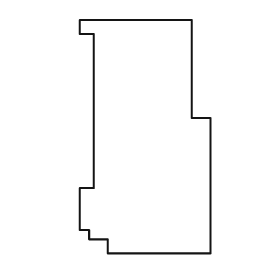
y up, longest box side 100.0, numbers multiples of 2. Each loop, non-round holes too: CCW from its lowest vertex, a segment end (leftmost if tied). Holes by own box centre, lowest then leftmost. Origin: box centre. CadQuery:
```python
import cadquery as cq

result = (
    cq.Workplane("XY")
    .moveTo(-16.0, -50.0)
    .lineTo(28.0, -50.0)
    .lineTo(28.0, 8.0)
    .lineTo(20.0, 8.0)
    .lineTo(20.0, 50.0)
    .lineTo(-28.0, 50.0)
    .lineTo(-28.0, 44.0)
    .lineTo(-22.0, 44.0)
    .lineTo(-22.0, -22.0)
    .lineTo(-28.0, -22.0)
    .lineTo(-28.0, -40.0)
    .lineTo(-24.0, -40.0)
    .lineTo(-24.0, -44.0)
    .lineTo(-16.0, -44.0)
    .close()
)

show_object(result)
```